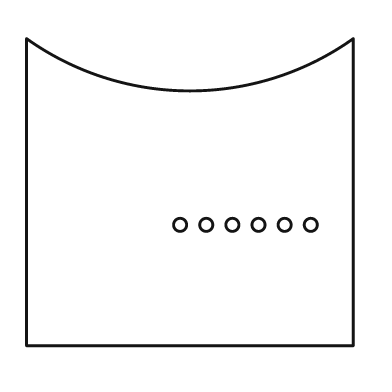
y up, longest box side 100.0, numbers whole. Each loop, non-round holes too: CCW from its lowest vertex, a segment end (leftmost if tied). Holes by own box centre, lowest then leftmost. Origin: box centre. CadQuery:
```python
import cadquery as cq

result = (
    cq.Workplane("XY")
    .moveTo(-50.0, -47.0)
    .lineTo(50.0, -47.0)
    .lineTo(50.0, 47.0)
    .threePointArc((0.0, 31.0), (-50.0, 47.0))
    .close()
    .moveTo(-3.0, -10.0)
    .circle(2.0)
    .moveTo(5.0, -10.0)
    .circle(2.0)
    .moveTo(13.0, -10.0)
    .circle(2.0)
    .moveTo(21.0, -10.0)
    .circle(2.0)
    .moveTo(29.0, -10.0)
    .circle(2.0)
    .moveTo(37.0, -10.0)
    .circle(2.0)
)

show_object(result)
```